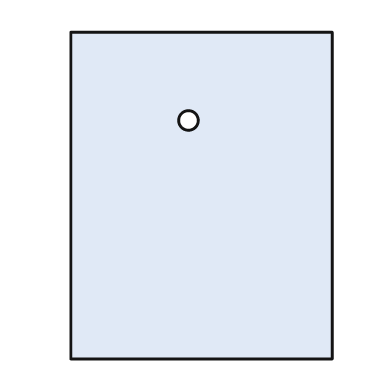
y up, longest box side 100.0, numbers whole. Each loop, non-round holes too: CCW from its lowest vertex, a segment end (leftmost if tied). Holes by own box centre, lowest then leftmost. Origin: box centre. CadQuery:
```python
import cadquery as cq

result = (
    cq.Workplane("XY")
    .moveTo(-40.0, -50.0)
    .lineTo(40.0, -50.0)
    .lineTo(40.0, 50.0)
    .lineTo(-40.0, 50.0)
    .close()
    .moveTo(-4.0, 23.0)
    .circle(3.0)
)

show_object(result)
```